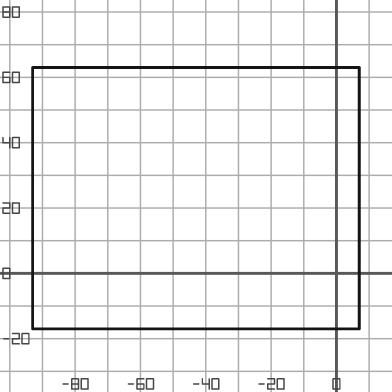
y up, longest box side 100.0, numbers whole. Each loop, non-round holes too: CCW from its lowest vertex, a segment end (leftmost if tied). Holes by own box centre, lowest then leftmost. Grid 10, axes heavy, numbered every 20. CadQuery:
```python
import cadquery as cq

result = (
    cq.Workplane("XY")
    .moveTo(-93.0, -17.0)
    .lineTo(7.0, -17.0)
    .lineTo(7.0, 63.0)
    .lineTo(-93.0, 63.0)
    .close()
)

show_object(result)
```